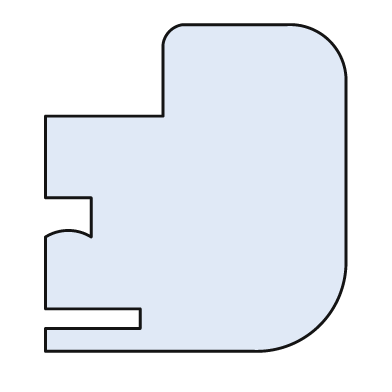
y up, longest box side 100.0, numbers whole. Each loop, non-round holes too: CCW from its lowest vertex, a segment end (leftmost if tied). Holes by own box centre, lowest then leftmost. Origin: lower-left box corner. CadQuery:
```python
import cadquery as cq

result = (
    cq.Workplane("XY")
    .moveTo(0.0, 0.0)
    .lineTo(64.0, 0.0)
    .threePointArc((84.0, 8.0), (92.0, 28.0))
    .lineTo(92.0, 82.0)
    .threePointArc((87.0, 95.0), (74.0, 100.0))
    .lineTo(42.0, 100.0)
    .threePointArc((38.0, 98.0), (36.0, 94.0))
    .lineTo(36.0, 72.0)
    .lineTo(0.0, 72.0)
    .lineTo(0.0, 47.0)
    .lineTo(14.0, 47.0)
    .lineTo(14.0, 35.0)
    .threePointArc((7.0, 37.0), (0.0, 35.0))
    .lineTo(0.0, 13.0)
    .lineTo(29.0, 13.0)
    .lineTo(29.0, 7.0)
    .lineTo(0.0, 7.0)
    .close()
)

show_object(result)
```